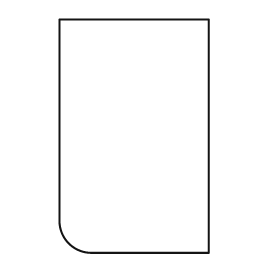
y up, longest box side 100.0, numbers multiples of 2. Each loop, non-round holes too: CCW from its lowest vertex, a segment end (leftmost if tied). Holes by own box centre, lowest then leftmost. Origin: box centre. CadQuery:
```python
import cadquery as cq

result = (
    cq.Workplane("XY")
    .moveTo(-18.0, -50.0)
    .lineTo(32.0, -50.0)
    .lineTo(32.0, 50.0)
    .lineTo(-32.0, 50.0)
    .lineTo(-32.0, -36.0)
    .threePointArc((-28.0, -46.0), (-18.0, -50.0))
    .close()
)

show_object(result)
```